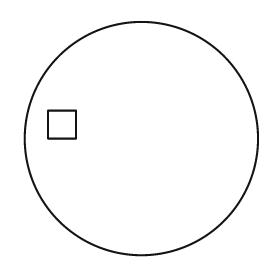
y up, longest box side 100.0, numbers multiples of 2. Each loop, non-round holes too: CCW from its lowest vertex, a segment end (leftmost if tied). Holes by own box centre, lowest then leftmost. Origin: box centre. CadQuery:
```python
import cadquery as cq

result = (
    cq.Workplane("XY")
    .moveTo(0.0, 0.0)
    .circle(50.0)
    .moveTo(-40.0, 0.0)
    .lineTo(-28.0, 0.0)
    .lineTo(-28.0, 12.0)
    .lineTo(-40.0, 12.0)
    .close()
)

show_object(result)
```